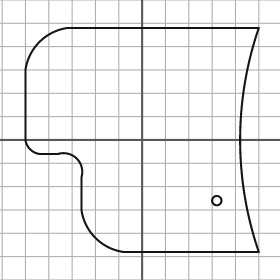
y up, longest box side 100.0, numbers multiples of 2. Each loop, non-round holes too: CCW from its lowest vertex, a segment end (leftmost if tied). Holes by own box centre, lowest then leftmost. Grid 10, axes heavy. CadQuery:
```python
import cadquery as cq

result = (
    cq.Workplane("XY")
    .moveTo(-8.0, -48.0)
    .lineTo(50.0, -48.0)
    .threePointArc((42.0, 0.0), (50.0, 48.0))
    .lineTo(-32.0, 48.0)
    .threePointArc((-44.0, 42.0), (-50.0, 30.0))
    .lineTo(-50.0, 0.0)
    .threePointArc((-48.0, -4.0), (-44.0, -6.0))
    .lineTo(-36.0, -6.0)
    .threePointArc((-28.0, -8.0), (-26.0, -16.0))
    .lineTo(-26.0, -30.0)
    .threePointArc((-20.0, -42.0), (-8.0, -48.0))
    .close()
    .moveTo(32.0, -26.0)
    .circle(2.0)
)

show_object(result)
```